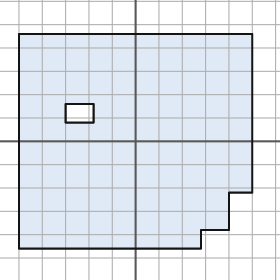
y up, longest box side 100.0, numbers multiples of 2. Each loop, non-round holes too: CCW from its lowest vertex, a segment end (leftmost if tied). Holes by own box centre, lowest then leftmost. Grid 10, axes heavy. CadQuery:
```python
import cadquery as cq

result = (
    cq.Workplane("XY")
    .moveTo(-50.0, -46.0)
    .lineTo(28.0, -46.0)
    .lineTo(28.0, -38.0)
    .lineTo(40.0, -38.0)
    .lineTo(40.0, -22.0)
    .lineTo(50.0, -22.0)
    .lineTo(50.0, 46.0)
    .lineTo(-50.0, 46.0)
    .close()
    .moveTo(-30.0, 8.0)
    .lineTo(-18.0, 8.0)
    .lineTo(-18.0, 16.0)
    .lineTo(-30.0, 16.0)
    .close()
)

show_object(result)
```